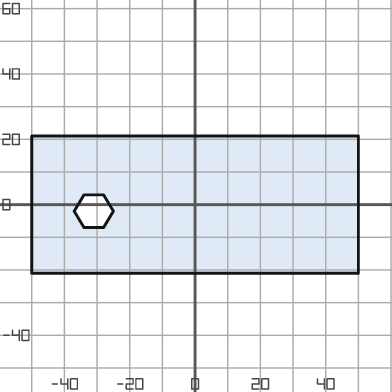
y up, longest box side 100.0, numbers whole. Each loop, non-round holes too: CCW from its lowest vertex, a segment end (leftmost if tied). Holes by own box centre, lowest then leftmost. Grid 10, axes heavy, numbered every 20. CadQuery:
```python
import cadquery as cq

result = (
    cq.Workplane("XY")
    .moveTo(-50.0, -21.0)
    .lineTo(50.0, -21.0)
    .lineTo(50.0, 21.0)
    .lineTo(-50.0, 21.0)
    .close()
    .moveTo(-34.0, -7.0)
    .lineTo(-28.0, -7.0)
    .lineTo(-25.0, -2.0)
    .lineTo(-28.0, 3.0)
    .lineTo(-34.0, 3.0)
    .lineTo(-37.0, -2.0)
    .close()
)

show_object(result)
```